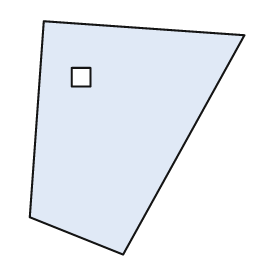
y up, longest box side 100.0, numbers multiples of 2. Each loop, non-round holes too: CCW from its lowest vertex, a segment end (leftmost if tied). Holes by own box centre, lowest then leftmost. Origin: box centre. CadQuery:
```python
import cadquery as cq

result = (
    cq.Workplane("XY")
    .moveTo(-6.0, -50.0)
    .lineTo(46.0, 44.0)
    .lineTo(-40.0, 50.0)
    .lineTo(-46.0, -34.0)
    .close()
    .moveTo(-28.0, 22.0)
    .lineTo(-20.0, 22.0)
    .lineTo(-20.0, 30.0)
    .lineTo(-28.0, 30.0)
    .close()
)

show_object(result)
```